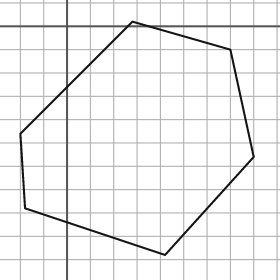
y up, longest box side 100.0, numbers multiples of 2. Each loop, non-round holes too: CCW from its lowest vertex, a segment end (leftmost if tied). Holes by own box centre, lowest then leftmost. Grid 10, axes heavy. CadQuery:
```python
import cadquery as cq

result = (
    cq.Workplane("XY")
    .moveTo(42.0, -98.0)
    .lineTo(80.0, -56.0)
    .lineTo(70.0, -10.0)
    .lineTo(28.0, 2.0)
    .lineTo(-20.0, -46.0)
    .lineTo(-18.0, -78.0)
    .close()
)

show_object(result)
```